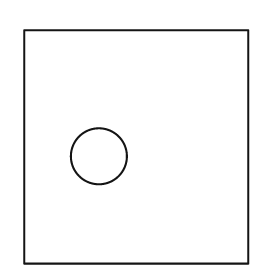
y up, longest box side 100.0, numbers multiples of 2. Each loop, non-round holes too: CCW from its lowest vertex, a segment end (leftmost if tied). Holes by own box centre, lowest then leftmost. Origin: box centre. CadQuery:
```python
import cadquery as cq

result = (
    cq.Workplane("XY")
    .moveTo(-48.0, -50.0)
    .lineTo(48.0, -50.0)
    .lineTo(48.0, 50.0)
    .lineTo(-48.0, 50.0)
    .close()
    .moveTo(-16.0, -4.0)
    .circle(12.0)
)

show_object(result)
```